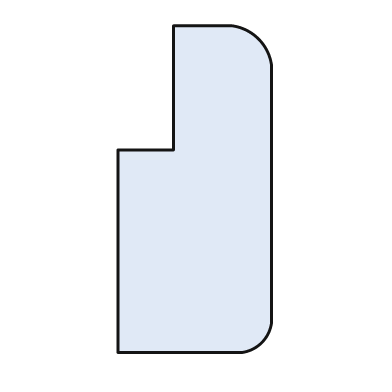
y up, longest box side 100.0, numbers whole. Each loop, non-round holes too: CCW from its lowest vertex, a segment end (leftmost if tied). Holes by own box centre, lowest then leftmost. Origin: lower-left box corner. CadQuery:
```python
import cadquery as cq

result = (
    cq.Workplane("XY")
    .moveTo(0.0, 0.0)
    .lineTo(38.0, 0.0)
    .threePointArc((44.0, 3.0), (47.0, 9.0))
    .lineTo(47.0, 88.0)
    .threePointArc((43.0, 96.0), (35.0, 100.0))
    .lineTo(17.0, 100.0)
    .lineTo(17.0, 62.0)
    .lineTo(0.0, 62.0)
    .close()
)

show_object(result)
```